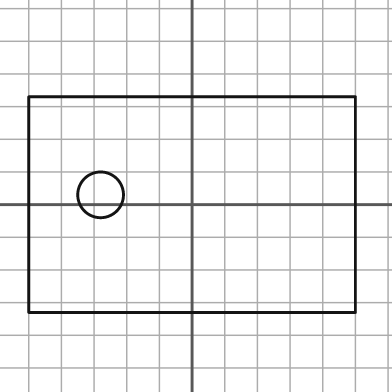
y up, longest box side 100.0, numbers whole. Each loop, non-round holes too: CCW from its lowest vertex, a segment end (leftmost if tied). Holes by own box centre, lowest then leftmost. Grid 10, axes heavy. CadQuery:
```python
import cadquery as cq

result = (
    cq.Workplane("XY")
    .moveTo(-50.0, -33.0)
    .lineTo(50.0, -33.0)
    .lineTo(50.0, 33.0)
    .lineTo(-50.0, 33.0)
    .close()
    .moveTo(-28.0, 3.0)
    .circle(7.0)
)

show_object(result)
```